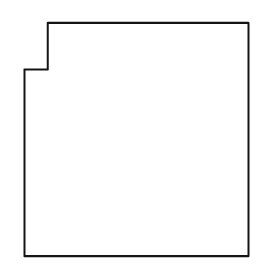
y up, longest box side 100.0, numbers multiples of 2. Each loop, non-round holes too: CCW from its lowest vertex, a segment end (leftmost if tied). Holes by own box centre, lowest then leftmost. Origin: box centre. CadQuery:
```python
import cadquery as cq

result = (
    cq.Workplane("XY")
    .moveTo(-48.0, -50.0)
    .lineTo(48.0, -50.0)
    .lineTo(48.0, 50.0)
    .lineTo(-38.0, 50.0)
    .lineTo(-38.0, 30.0)
    .lineTo(-48.0, 30.0)
    .close()
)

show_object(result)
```